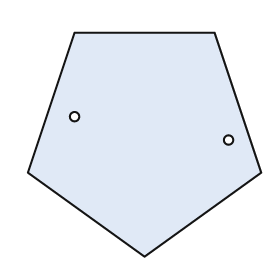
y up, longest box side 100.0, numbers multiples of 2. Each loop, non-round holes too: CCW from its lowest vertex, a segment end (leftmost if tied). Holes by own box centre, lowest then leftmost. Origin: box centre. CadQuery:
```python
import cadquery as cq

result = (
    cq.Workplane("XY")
    .moveTo(0.0, -48.0)
    .lineTo(50.0, -12.0)
    .lineTo(30.0, 48.0)
    .lineTo(-30.0, 48.0)
    .lineTo(-50.0, -12.0)
    .close()
    .moveTo(36.0, 2.0)
    .circle(2.0)
    .moveTo(-30.0, 12.0)
    .circle(2.0)
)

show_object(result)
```